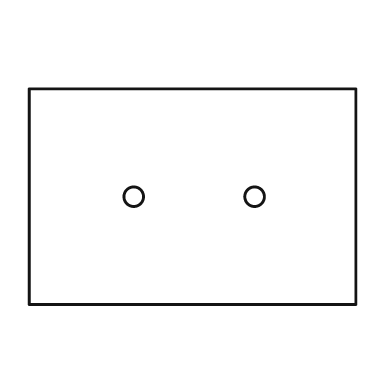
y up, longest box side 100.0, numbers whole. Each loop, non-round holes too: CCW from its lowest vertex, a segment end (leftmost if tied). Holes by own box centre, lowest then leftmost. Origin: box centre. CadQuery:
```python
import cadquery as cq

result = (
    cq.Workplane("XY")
    .moveTo(-50.0, -33.0)
    .lineTo(50.0, -33.0)
    .lineTo(50.0, 33.0)
    .lineTo(-50.0, 33.0)
    .close()
    .moveTo(-18.0, 0.0)
    .circle(3.0)
    .moveTo(19.0, 0.0)
    .circle(3.0)
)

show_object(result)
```